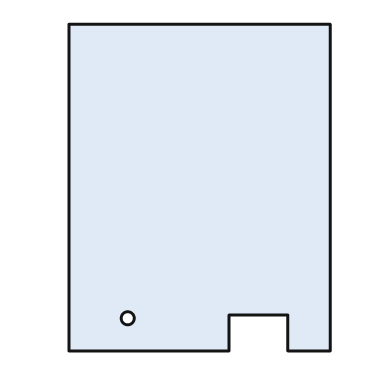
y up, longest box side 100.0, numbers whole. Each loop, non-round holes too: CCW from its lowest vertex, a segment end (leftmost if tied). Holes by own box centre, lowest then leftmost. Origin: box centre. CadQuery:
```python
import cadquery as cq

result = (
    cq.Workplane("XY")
    .moveTo(-40.0, -50.0)
    .lineTo(9.0, -50.0)
    .lineTo(9.0, -39.0)
    .lineTo(27.0, -39.0)
    .lineTo(27.0, -50.0)
    .lineTo(40.0, -50.0)
    .lineTo(40.0, 50.0)
    .lineTo(-40.0, 50.0)
    .close()
    .moveTo(-22.0, -40.0)
    .circle(2.0)
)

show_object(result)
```